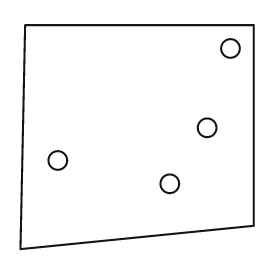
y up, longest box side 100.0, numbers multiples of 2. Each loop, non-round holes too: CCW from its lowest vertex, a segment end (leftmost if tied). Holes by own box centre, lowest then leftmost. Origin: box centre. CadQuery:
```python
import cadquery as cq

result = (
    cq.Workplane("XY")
    .moveTo(-50.0, -48.0)
    .lineTo(50.0, -38.0)
    .lineTo(50.0, 48.0)
    .lineTo(-48.0, 48.0)
    .close()
    .moveTo(14.0, -20.0)
    .circle(4.0)
    .moveTo(-34.0, -10.0)
    .circle(4.0)
    .moveTo(30.0, 4.0)
    .circle(4.0)
    .moveTo(40.0, 38.0)
    .circle(4.0)
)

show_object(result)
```